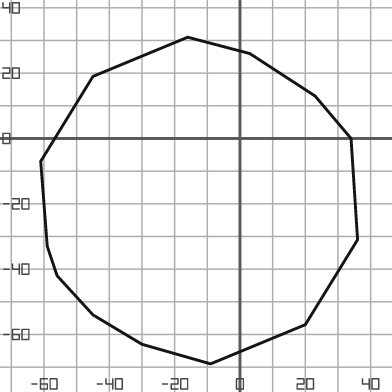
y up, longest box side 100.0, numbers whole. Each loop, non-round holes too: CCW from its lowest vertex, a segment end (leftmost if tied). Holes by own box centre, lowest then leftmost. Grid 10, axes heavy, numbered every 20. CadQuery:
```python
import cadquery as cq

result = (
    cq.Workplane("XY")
    .moveTo(-9.0, -69.0)
    .lineTo(20.0, -57.0)
    .lineTo(36.0, -31.0)
    .lineTo(34.0, 0.0)
    .lineTo(23.0, 13.0)
    .lineTo(3.0, 26.0)
    .lineTo(-16.0, 31.0)
    .lineTo(-45.0, 19.0)
    .lineTo(-61.0, -7.0)
    .lineTo(-59.0, -33.0)
    .lineTo(-56.0, -42.0)
    .lineTo(-45.0, -54.0)
    .lineTo(-30.0, -63.0)
    .close()
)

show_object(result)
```